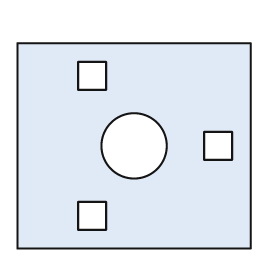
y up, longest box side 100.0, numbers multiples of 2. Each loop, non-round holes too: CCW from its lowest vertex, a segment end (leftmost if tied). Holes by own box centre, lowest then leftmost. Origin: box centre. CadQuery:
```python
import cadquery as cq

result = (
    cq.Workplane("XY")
    .moveTo(-50.0, -44.0)
    .lineTo(50.0, -44.0)
    .lineTo(50.0, 44.0)
    .lineTo(-50.0, 44.0)
    .close()
    .moveTo(-24.0, -36.0)
    .lineTo(-12.0, -36.0)
    .lineTo(-12.0, -24.0)
    .lineTo(-24.0, -24.0)
    .close()
    .moveTo(0.0, 0.0)
    .circle(14.0)
    .moveTo(30.0, -6.0)
    .lineTo(42.0, -6.0)
    .lineTo(42.0, 6.0)
    .lineTo(30.0, 6.0)
    .close()
    .moveTo(-24.0, 24.0)
    .lineTo(-12.0, 24.0)
    .lineTo(-12.0, 36.0)
    .lineTo(-24.0, 36.0)
    .close()
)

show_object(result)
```